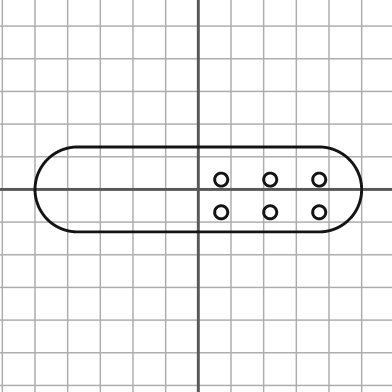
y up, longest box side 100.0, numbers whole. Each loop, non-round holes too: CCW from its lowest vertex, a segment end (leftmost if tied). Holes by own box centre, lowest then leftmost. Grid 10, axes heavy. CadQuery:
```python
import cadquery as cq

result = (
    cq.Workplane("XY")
    .moveTo(-37.0, -13.0)
    .lineTo(37.0, -13.0)
    .threePointArc((50.0, 0.0), (37.0, 13.0))
    .lineTo(-37.0, 13.0)
    .threePointArc((-50.0, 0.0), (-37.0, -13.0))
    .close()
    .moveTo(7.0, -7.0)
    .circle(2.0)
    .moveTo(22.0, -7.0)
    .circle(2.0)
    .moveTo(37.0, -7.0)
    .circle(2.0)
    .moveTo(7.0, 3.0)
    .circle(2.0)
    .moveTo(22.0, 3.0)
    .circle(2.0)
    .moveTo(37.0, 3.0)
    .circle(2.0)
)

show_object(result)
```